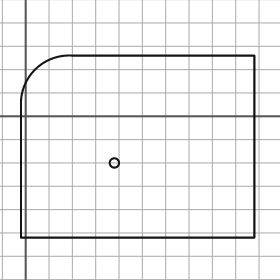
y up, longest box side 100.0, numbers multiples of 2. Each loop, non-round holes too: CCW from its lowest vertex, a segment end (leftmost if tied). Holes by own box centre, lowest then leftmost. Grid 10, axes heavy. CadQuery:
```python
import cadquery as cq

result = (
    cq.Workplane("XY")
    .moveTo(-2.0, -52.0)
    .lineTo(98.0, -52.0)
    .lineTo(98.0, 26.0)
    .lineTo(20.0, 26.0)
    .threePointArc((4.0, 20.0), (-2.0, 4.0))
    .close()
    .moveTo(38.0, -20.0)
    .circle(2.0)
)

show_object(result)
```